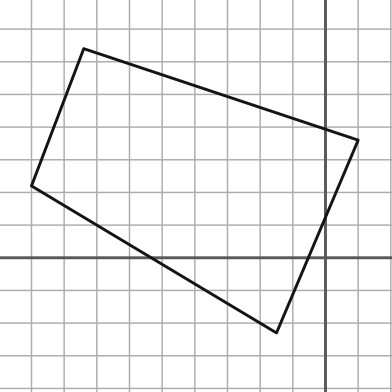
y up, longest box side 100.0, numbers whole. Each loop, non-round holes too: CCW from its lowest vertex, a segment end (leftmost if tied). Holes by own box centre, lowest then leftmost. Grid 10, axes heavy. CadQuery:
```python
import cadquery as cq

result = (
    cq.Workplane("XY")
    .moveTo(-15.0, -23.0)
    .lineTo(10.0, 36.0)
    .lineTo(-74.0, 64.0)
    .lineTo(-90.0, 22.0)
    .close()
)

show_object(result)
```